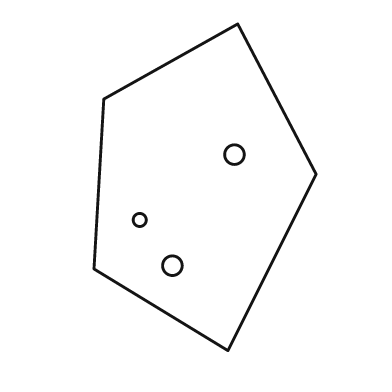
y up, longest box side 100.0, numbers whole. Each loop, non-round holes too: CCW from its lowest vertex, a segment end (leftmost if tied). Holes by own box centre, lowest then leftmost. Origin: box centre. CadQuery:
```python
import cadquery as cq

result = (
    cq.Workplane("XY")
    .moveTo(7.0, -50.0)
    .lineTo(34.0, 4.0)
    .lineTo(10.0, 50.0)
    .lineTo(-31.0, 27.0)
    .lineTo(-34.0, -25.0)
    .close()
    .moveTo(-10.0, -24.0)
    .circle(3.0)
    .moveTo(-20.0, -10.0)
    .circle(2.0)
    .moveTo(9.0, 10.0)
    .circle(3.0)
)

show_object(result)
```